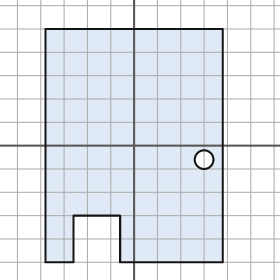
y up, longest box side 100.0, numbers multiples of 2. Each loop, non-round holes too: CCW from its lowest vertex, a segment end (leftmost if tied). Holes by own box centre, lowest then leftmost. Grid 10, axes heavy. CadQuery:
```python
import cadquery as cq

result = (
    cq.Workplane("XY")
    .moveTo(-38.0, -50.0)
    .lineTo(-26.0, -50.0)
    .lineTo(-26.0, -30.0)
    .lineTo(-6.0, -30.0)
    .lineTo(-6.0, -50.0)
    .lineTo(38.0, -50.0)
    .lineTo(38.0, 50.0)
    .lineTo(-38.0, 50.0)
    .close()
    .moveTo(30.0, -6.0)
    .circle(4.0)
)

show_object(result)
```